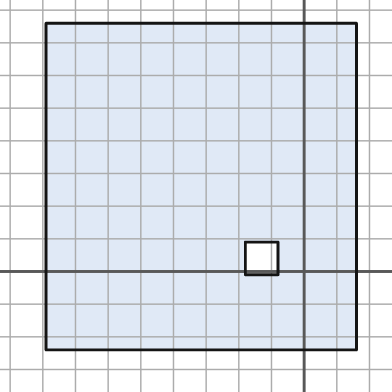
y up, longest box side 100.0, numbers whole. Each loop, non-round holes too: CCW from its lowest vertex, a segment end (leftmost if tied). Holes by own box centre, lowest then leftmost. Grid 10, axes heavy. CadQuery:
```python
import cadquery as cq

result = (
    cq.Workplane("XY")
    .moveTo(-79.0, -24.0)
    .lineTo(16.0, -24.0)
    .lineTo(16.0, 76.0)
    .lineTo(-79.0, 76.0)
    .close()
    .moveTo(-18.0, -1.0)
    .lineTo(-8.0, -1.0)
    .lineTo(-8.0, 9.0)
    .lineTo(-18.0, 9.0)
    .close()
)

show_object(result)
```